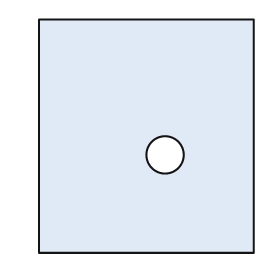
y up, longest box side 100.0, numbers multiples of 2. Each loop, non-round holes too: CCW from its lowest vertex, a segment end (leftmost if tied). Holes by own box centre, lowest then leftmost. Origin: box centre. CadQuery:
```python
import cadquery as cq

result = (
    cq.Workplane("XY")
    .moveTo(-46.0, -50.0)
    .lineTo(46.0, -50.0)
    .lineTo(46.0, 50.0)
    .lineTo(-46.0, 50.0)
    .close()
    .moveTo(8.0, -8.0)
    .circle(8.0)
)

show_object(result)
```